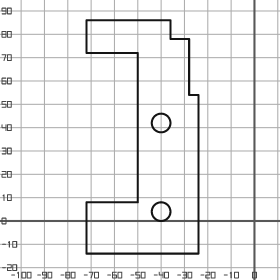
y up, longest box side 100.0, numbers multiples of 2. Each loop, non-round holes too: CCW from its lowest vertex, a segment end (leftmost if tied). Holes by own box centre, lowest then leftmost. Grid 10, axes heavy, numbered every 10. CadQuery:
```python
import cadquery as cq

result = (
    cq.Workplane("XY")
    .moveTo(-72.0, -14.0)
    .lineTo(-24.0, -14.0)
    .lineTo(-24.0, 54.0)
    .lineTo(-28.0, 54.0)
    .lineTo(-28.0, 78.0)
    .lineTo(-36.0, 78.0)
    .lineTo(-36.0, 86.0)
    .lineTo(-72.0, 86.0)
    .lineTo(-72.0, 72.0)
    .lineTo(-50.0, 72.0)
    .lineTo(-50.0, 8.0)
    .lineTo(-72.0, 8.0)
    .close()
    .moveTo(-40.0, 4.0)
    .circle(4.0)
    .moveTo(-40.0, 42.0)
    .circle(4.0)
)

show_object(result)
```